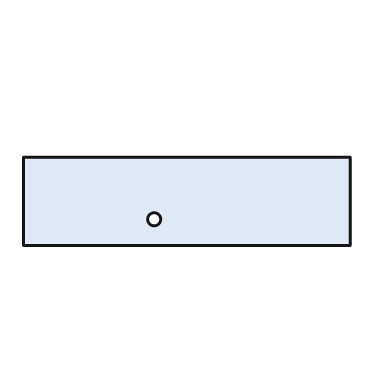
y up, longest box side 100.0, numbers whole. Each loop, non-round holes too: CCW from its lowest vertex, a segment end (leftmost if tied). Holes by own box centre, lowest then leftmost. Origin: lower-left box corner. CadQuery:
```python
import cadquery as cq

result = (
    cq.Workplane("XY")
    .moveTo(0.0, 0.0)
    .lineTo(100.0, 0.0)
    .lineTo(100.0, 27.0)
    .lineTo(0.0, 27.0)
    .close()
    .moveTo(40.0, 8.0)
    .circle(2.0)
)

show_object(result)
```